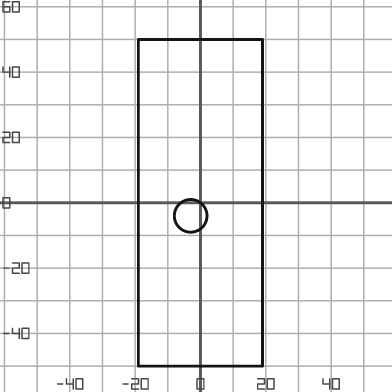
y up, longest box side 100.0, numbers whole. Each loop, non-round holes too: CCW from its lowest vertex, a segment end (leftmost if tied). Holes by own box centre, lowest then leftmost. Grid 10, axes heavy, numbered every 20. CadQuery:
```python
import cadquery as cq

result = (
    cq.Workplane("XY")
    .moveTo(-19.0, -50.0)
    .lineTo(19.0, -50.0)
    .lineTo(19.0, 50.0)
    .lineTo(-19.0, 50.0)
    .close()
    .moveTo(-3.0, -4.0)
    .circle(5.0)
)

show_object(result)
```